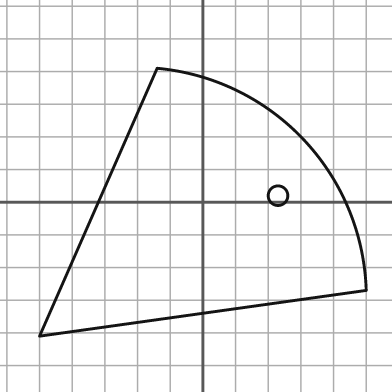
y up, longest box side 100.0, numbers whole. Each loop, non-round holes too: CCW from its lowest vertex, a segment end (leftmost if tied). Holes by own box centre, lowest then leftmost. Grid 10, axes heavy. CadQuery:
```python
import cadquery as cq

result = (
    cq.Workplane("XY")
    .moveTo(-50.0, -41.0)
    .lineTo(50.0, -27.0)
    .threePointArc((31.0, 19.0), (-14.0, 41.0))
    .close()
    .moveTo(23.0, 2.0)
    .circle(3.0)
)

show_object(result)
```